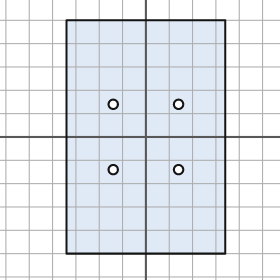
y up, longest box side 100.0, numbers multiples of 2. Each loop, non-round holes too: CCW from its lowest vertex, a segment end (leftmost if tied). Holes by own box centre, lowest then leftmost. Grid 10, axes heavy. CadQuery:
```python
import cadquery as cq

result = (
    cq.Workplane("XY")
    .moveTo(-34.0, -50.0)
    .lineTo(34.0, -50.0)
    .lineTo(34.0, 50.0)
    .lineTo(-34.0, 50.0)
    .close()
    .moveTo(-14.0, -14.0)
    .circle(2.0)
    .moveTo(14.0, -14.0)
    .circle(2.0)
    .moveTo(-14.0, 14.0)
    .circle(2.0)
    .moveTo(14.0, 14.0)
    .circle(2.0)
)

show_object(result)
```